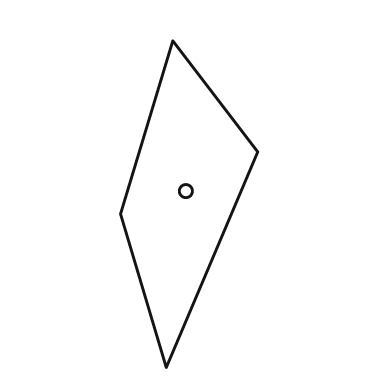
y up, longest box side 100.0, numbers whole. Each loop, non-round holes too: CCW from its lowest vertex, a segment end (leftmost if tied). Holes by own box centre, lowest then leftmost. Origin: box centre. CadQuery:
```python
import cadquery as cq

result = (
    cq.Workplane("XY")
    .moveTo(-7.0, -50.0)
    .lineTo(21.0, 16.0)
    .lineTo(-5.0, 50.0)
    .lineTo(-21.0, -3.0)
    .close()
    .moveTo(-1.0, 4.0)
    .circle(2.0)
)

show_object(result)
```